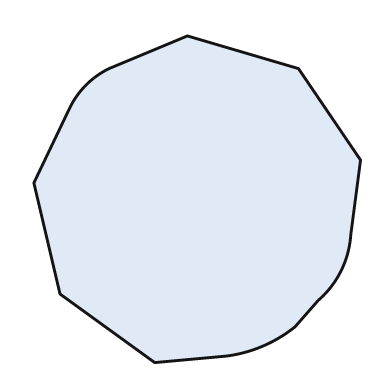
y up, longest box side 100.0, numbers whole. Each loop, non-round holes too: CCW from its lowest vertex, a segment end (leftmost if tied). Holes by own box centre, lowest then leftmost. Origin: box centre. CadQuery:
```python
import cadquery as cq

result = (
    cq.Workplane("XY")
    .moveTo(-13.0, -50.0)
    .lineTo(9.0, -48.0)
    .threePointArc((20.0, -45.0), (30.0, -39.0))
    .lineTo(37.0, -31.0)
    .threePointArc((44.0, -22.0), (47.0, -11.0))
    .lineTo(50.0, 12.0)
    .lineTo(31.0, 40.0)
    .lineTo(-3.0, 50.0)
    .lineTo(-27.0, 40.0)
    .threePointArc((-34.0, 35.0), (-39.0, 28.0))
    .lineTo(-50.0, 5.0)
    .lineTo(-42.0, -29.0)
    .close()
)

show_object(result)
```